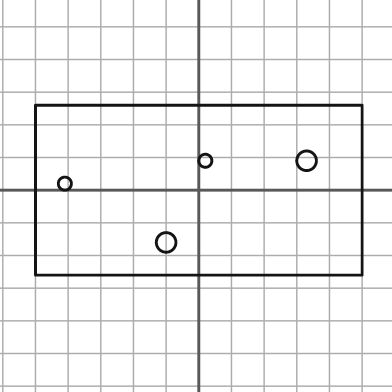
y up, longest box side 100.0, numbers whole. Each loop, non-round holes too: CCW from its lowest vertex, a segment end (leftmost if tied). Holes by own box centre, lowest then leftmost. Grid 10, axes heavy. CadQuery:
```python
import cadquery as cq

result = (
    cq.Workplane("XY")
    .moveTo(-50.0, -26.0)
    .lineTo(50.0, -26.0)
    .lineTo(50.0, 26.0)
    .lineTo(-50.0, 26.0)
    .close()
    .moveTo(-10.0, -16.0)
    .circle(3.0)
    .moveTo(-41.0, 2.0)
    .circle(2.0)
    .moveTo(2.0, 9.0)
    .circle(2.0)
    .moveTo(33.0, 9.0)
    .circle(3.0)
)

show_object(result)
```